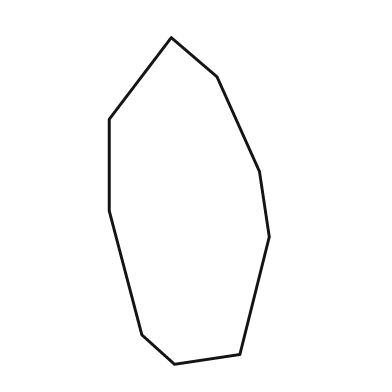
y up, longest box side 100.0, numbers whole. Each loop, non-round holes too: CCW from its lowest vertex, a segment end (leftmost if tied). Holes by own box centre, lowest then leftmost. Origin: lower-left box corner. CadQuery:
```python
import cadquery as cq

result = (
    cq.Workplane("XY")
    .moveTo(20.0, 0.0)
    .lineTo(40.0, 3.0)
    .lineTo(49.0, 39.0)
    .lineTo(46.0, 59.0)
    .lineTo(33.0, 88.0)
    .lineTo(19.0, 100.0)
    .lineTo(0.0, 75.0)
    .lineTo(0.0, 47.0)
    .lineTo(10.0, 9.0)
    .close()
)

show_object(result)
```